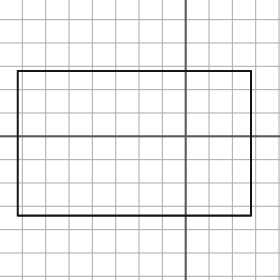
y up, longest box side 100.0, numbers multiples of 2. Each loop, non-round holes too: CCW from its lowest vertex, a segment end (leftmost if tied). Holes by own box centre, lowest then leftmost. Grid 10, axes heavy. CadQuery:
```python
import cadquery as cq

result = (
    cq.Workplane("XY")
    .moveTo(-72.0, -34.0)
    .lineTo(28.0, -34.0)
    .lineTo(28.0, 28.0)
    .lineTo(-72.0, 28.0)
    .close()
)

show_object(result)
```